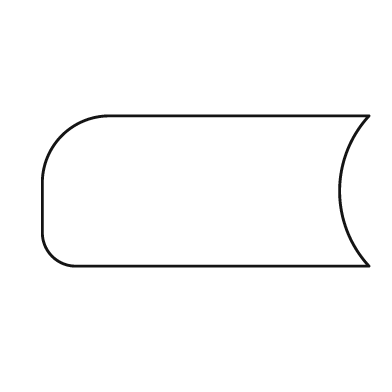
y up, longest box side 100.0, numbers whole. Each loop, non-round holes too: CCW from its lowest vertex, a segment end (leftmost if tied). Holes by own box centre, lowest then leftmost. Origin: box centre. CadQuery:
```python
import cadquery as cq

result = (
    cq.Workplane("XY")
    .moveTo(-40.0, -23.0)
    .lineTo(50.0, -23.0)
    .threePointArc((41.0, 0.0), (50.0, 23.0))
    .lineTo(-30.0, 23.0)
    .threePointArc((-44.0, 17.0), (-50.0, 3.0))
    .lineTo(-50.0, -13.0)
    .threePointArc((-47.0, -20.0), (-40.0, -23.0))
    .close()
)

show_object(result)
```